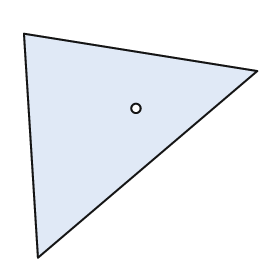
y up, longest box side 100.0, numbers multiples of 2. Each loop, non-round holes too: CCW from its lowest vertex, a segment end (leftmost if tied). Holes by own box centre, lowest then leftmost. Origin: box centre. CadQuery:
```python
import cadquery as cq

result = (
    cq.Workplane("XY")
    .moveTo(-44.0, -48.0)
    .lineTo(50.0, 32.0)
    .lineTo(-50.0, 48.0)
    .close()
    .moveTo(-2.0, 16.0)
    .circle(2.0)
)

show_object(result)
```